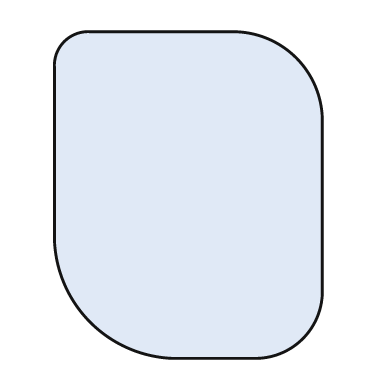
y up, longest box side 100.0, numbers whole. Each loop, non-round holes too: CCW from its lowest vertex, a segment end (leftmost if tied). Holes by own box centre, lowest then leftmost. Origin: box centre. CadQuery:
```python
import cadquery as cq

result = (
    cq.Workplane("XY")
    .moveTo(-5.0, -50.0)
    .lineTo(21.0, -50.0)
    .threePointArc((35.0, -44.0), (41.0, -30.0))
    .lineTo(41.0, 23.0)
    .threePointArc((33.0, 42.0), (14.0, 50.0))
    .lineTo(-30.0, 50.0)
    .threePointArc((-38.0, 47.0), (-41.0, 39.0))
    .lineTo(-41.0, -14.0)
    .threePointArc((-30.0, -39.0), (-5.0, -50.0))
    .close()
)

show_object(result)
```